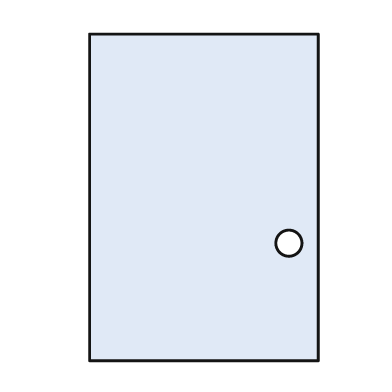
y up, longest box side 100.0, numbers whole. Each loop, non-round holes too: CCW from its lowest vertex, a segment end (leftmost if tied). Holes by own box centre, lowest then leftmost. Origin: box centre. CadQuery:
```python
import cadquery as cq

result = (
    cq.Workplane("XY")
    .moveTo(-35.0, -50.0)
    .lineTo(35.0, -50.0)
    .lineTo(35.0, 50.0)
    .lineTo(-35.0, 50.0)
    .close()
    .moveTo(26.0, -14.0)
    .circle(4.0)
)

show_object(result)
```